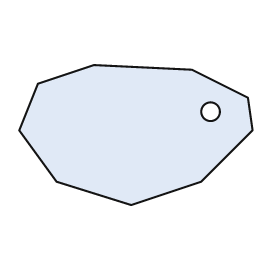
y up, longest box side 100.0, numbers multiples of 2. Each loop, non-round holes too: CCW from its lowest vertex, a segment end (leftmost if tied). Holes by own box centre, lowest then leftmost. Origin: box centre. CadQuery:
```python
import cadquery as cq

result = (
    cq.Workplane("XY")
    .moveTo(-2.0, -30.0)
    .lineTo(28.0, -20.0)
    .lineTo(50.0, 2.0)
    .lineTo(48.0, 16.0)
    .lineTo(24.0, 28.0)
    .lineTo(-18.0, 30.0)
    .lineTo(-42.0, 22.0)
    .lineTo(-50.0, 2.0)
    .lineTo(-34.0, -20.0)
    .close()
    .moveTo(32.0, 10.0)
    .circle(4.0)
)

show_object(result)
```